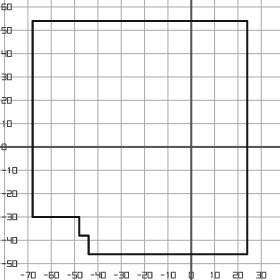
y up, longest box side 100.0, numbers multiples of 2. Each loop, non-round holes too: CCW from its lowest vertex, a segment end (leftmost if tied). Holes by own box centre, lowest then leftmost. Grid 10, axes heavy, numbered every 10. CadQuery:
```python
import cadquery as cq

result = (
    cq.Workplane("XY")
    .moveTo(-44.0, -46.0)
    .lineTo(24.0, -46.0)
    .lineTo(24.0, 54.0)
    .lineTo(-68.0, 54.0)
    .lineTo(-68.0, -30.0)
    .lineTo(-48.0, -30.0)
    .lineTo(-48.0, -38.0)
    .lineTo(-44.0, -38.0)
    .close()
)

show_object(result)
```